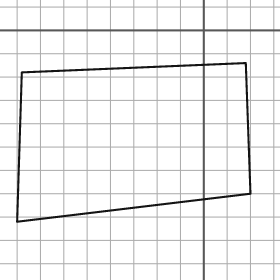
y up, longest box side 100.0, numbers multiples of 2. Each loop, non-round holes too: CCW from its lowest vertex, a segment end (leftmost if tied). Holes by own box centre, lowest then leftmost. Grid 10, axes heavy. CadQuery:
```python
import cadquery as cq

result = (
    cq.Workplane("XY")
    .moveTo(-80.0, -82.0)
    .lineTo(20.0, -70.0)
    .lineTo(18.0, -14.0)
    .lineTo(-78.0, -18.0)
    .close()
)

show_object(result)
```